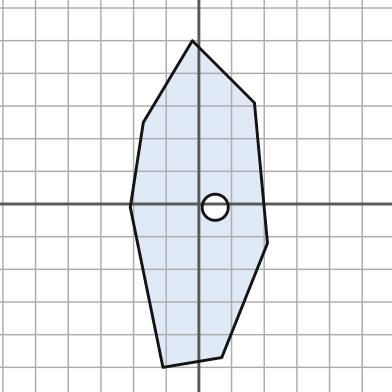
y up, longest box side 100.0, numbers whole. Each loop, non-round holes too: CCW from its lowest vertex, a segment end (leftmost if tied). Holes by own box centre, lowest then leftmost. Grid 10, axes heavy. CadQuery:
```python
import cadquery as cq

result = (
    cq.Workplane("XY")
    .moveTo(-11.0, -50.0)
    .lineTo(7.0, -47.0)
    .lineTo(21.0, -12.0)
    .lineTo(17.0, 31.0)
    .lineTo(-2.0, 50.0)
    .lineTo(-17.0, 25.0)
    .lineTo(-21.0, -1.0)
    .close()
    .moveTo(5.0, -1.0)
    .circle(4.0)
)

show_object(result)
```